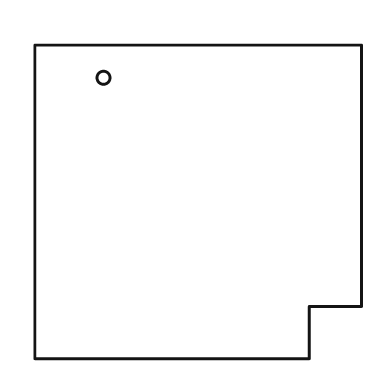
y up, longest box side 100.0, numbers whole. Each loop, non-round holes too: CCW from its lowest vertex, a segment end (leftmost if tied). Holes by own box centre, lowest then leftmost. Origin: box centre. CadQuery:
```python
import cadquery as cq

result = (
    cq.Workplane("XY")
    .moveTo(-50.0, -48.0)
    .lineTo(34.0, -48.0)
    .lineTo(34.0, -32.0)
    .lineTo(50.0, -32.0)
    .lineTo(50.0, 48.0)
    .lineTo(-50.0, 48.0)
    .close()
    .moveTo(-29.0, 38.0)
    .circle(2.0)
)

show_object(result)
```